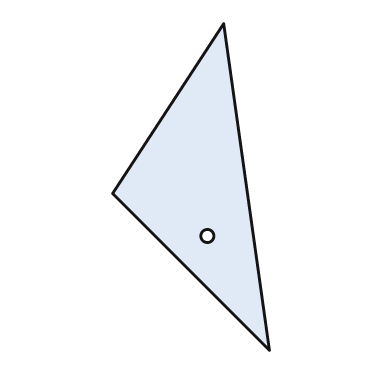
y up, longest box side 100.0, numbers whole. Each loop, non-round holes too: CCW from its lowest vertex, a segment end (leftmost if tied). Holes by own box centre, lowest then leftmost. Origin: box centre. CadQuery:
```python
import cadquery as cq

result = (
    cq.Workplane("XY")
    .moveTo(24.0, -50.0)
    .lineTo(10.0, 50.0)
    .lineTo(-24.0, -2.0)
    .close()
    .moveTo(5.0, -15.0)
    .circle(2.0)
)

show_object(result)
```